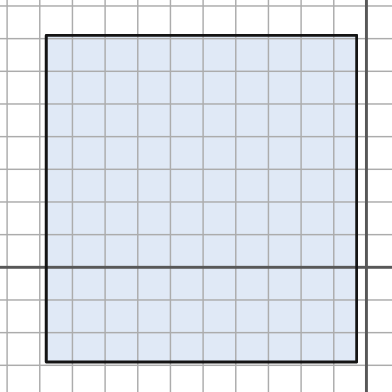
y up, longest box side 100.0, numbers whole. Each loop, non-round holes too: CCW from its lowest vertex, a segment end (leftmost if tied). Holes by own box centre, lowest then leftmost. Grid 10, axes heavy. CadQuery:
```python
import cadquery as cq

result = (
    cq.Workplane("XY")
    .moveTo(-98.0, -29.0)
    .lineTo(-3.0, -29.0)
    .lineTo(-3.0, 71.0)
    .lineTo(-98.0, 71.0)
    .close()
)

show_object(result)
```